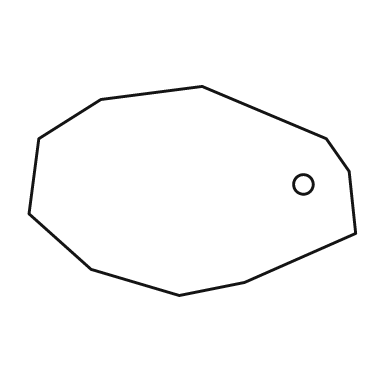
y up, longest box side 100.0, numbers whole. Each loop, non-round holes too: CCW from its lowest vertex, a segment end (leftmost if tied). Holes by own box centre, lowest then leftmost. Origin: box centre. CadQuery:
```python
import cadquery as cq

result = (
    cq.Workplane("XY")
    .moveTo(-4.0, -32.0)
    .lineTo(16.0, -28.0)
    .lineTo(50.0, -13.0)
    .lineTo(48.0, 6.0)
    .lineTo(41.0, 16.0)
    .lineTo(3.0, 32.0)
    .lineTo(-28.0, 28.0)
    .lineTo(-47.0, 16.0)
    .lineTo(-50.0, -7.0)
    .lineTo(-31.0, -24.0)
    .close()
    .moveTo(34.0, 2.0)
    .circle(3.0)
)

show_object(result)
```